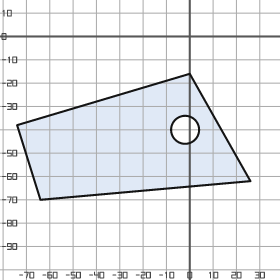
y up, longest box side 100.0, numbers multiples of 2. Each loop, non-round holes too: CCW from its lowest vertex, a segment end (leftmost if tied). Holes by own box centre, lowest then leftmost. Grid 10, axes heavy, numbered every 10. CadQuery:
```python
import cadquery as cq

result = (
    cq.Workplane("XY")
    .moveTo(-64.0, -70.0)
    .lineTo(26.0, -62.0)
    .lineTo(0.0, -16.0)
    .lineTo(-74.0, -38.0)
    .close()
    .moveTo(-2.0, -40.0)
    .circle(6.0)
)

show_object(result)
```